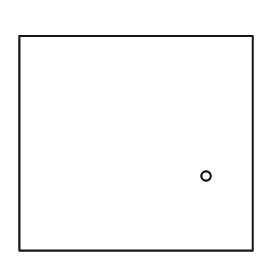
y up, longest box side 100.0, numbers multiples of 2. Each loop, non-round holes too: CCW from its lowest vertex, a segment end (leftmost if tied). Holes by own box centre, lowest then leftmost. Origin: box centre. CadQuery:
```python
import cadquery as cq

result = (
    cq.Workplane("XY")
    .moveTo(-50.0, -46.0)
    .lineTo(50.0, -46.0)
    .lineTo(50.0, 46.0)
    .lineTo(-50.0, 46.0)
    .close()
    .moveTo(30.0, -14.0)
    .circle(2.0)
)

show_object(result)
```